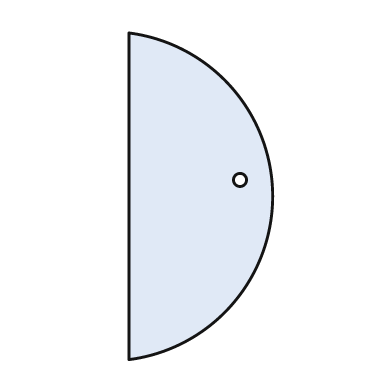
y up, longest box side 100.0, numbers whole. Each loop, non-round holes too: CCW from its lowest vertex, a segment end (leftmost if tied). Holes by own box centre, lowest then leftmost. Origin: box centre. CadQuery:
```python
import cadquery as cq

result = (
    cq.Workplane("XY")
    .moveTo(-22.0, -50.0)
    .threePointArc((22.0, 0.0), (-22.0, 50.0))
    .close()
    .moveTo(12.0, 5.0)
    .circle(2.0)
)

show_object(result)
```